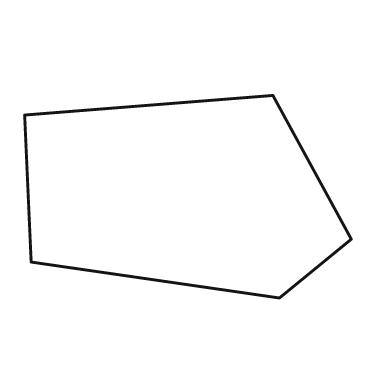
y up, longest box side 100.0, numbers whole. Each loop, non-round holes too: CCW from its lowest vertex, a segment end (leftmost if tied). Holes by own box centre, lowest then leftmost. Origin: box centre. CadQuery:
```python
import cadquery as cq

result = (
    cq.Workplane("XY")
    .moveTo(28.0, -31.0)
    .lineTo(50.0, -13.0)
    .lineTo(26.0, 31.0)
    .lineTo(-50.0, 25.0)
    .lineTo(-48.0, -20.0)
    .close()
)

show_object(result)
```